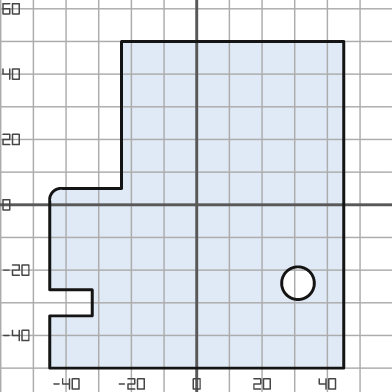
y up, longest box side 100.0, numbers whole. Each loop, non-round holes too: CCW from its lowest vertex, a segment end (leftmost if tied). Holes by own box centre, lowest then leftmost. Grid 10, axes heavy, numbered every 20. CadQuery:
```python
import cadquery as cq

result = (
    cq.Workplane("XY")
    .moveTo(-45.0, -50.0)
    .lineTo(45.0, -50.0)
    .lineTo(45.0, 50.0)
    .lineTo(-23.0, 50.0)
    .lineTo(-23.0, 5.0)
    .lineTo(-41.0, 5.0)
    .threePointArc((-44.0, 4.0), (-45.0, 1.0))
    .lineTo(-45.0, -26.0)
    .lineTo(-32.0, -26.0)
    .lineTo(-32.0, -34.0)
    .lineTo(-45.0, -34.0)
    .close()
    .moveTo(31.0, -24.0)
    .circle(5.0)
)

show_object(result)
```